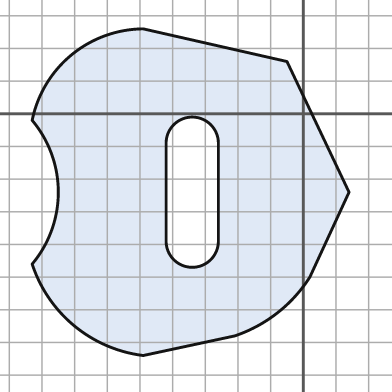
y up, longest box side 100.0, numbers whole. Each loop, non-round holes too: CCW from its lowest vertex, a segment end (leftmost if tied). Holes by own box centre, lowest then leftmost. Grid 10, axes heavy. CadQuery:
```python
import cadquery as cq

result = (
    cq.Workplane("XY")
    .moveTo(-49.0, -74.0)
    .lineTo(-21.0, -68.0)
    .threePointArc((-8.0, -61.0), (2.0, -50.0))
    .lineTo(14.0, -24.0)
    .lineTo(-5.0, 16.0)
    .lineTo(-49.0, 26.0)
    .threePointArc((-71.0, 18.0), (-83.0, -2.0))
    .threePointArc((-75.0, -24.0), (-83.0, -46.0))
    .threePointArc((-70.0, -65.0), (-49.0, -74.0))
    .close()
    .moveTo(-42.0, -39.0)
    .threePointArc((-34.0, -47.0), (-26.0, -39.0))
    .lineTo(-26.0, -9.0)
    .threePointArc((-34.0, -1.0), (-42.0, -9.0))
    .close()
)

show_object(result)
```